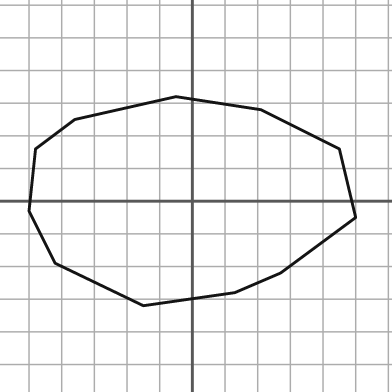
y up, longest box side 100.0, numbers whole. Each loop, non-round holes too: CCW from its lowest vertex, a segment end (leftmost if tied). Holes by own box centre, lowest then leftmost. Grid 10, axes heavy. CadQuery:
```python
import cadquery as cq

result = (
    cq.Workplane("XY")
    .moveTo(-15.0, -32.0)
    .lineTo(13.0, -28.0)
    .lineTo(27.0, -22.0)
    .lineTo(50.0, -5.0)
    .lineTo(45.0, 16.0)
    .lineTo(21.0, 28.0)
    .lineTo(-5.0, 32.0)
    .lineTo(-36.0, 25.0)
    .lineTo(-48.0, 16.0)
    .lineTo(-50.0, -3.0)
    .lineTo(-42.0, -19.0)
    .close()
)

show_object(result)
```